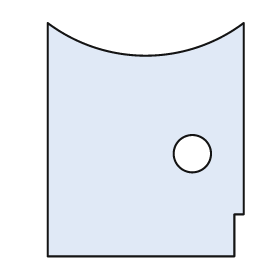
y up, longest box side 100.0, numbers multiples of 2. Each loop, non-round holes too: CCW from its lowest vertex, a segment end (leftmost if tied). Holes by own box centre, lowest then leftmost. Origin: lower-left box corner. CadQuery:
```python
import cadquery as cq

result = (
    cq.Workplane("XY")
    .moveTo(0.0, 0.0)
    .lineTo(80.0, 0.0)
    .lineTo(80.0, 18.0)
    .lineTo(84.0, 18.0)
    .lineTo(84.0, 100.0)
    .threePointArc((42.0, 86.0), (0.0, 100.0))
    .close()
    .moveTo(62.0, 44.0)
    .circle(8.0)
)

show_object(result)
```